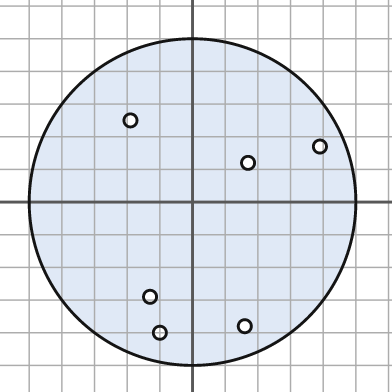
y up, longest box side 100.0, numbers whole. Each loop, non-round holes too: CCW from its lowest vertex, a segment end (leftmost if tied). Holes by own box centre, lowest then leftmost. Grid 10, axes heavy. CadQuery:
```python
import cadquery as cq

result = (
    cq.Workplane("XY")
    .moveTo(0.0, 0.0)
    .circle(50.0)
    .moveTo(-10.0, -40.0)
    .circle(2.0)
    .moveTo(16.0, -38.0)
    .circle(2.0)
    .moveTo(-13.0, -29.0)
    .circle(2.0)
    .moveTo(17.0, 12.0)
    .circle(2.0)
    .moveTo(39.0, 17.0)
    .circle(2.0)
    .moveTo(-19.0, 25.0)
    .circle(2.0)
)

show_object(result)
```